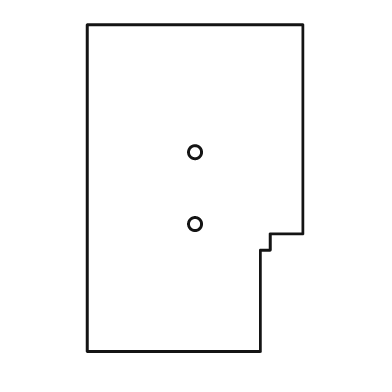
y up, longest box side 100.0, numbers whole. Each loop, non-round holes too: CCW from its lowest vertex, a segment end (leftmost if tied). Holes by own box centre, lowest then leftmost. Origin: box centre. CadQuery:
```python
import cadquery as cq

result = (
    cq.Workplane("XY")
    .moveTo(-33.0, -50.0)
    .lineTo(20.0, -50.0)
    .lineTo(20.0, -19.0)
    .lineTo(23.0, -19.0)
    .lineTo(23.0, -14.0)
    .lineTo(33.0, -14.0)
    .lineTo(33.0, 50.0)
    .lineTo(-33.0, 50.0)
    .close()
    .moveTo(0.0, -11.0)
    .circle(2.0)
    .moveTo(0.0, 11.0)
    .circle(2.0)
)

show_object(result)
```